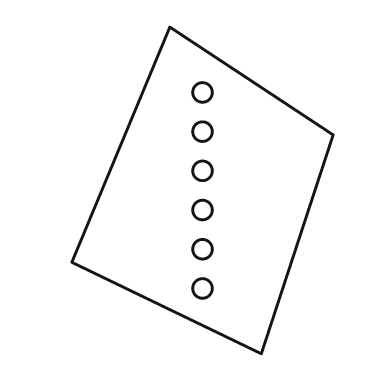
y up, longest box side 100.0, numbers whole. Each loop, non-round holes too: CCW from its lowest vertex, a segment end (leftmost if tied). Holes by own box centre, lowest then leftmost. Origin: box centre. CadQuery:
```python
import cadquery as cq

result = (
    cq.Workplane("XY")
    .moveTo(18.0, -50.0)
    .lineTo(40.0, 17.0)
    .lineTo(-10.0, 50.0)
    .lineTo(-40.0, -22.0)
    .close()
    .moveTo(0.0, -30.0)
    .circle(3.0)
    .moveTo(0.0, -18.0)
    .circle(3.0)
    .moveTo(0.0, -6.0)
    .circle(3.0)
    .moveTo(0.0, 6.0)
    .circle(3.0)
    .moveTo(0.0, 18.0)
    .circle(3.0)
    .moveTo(0.0, 30.0)
    .circle(3.0)
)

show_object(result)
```